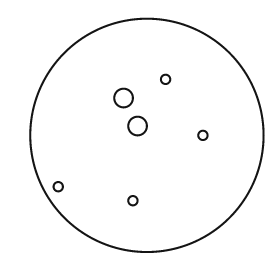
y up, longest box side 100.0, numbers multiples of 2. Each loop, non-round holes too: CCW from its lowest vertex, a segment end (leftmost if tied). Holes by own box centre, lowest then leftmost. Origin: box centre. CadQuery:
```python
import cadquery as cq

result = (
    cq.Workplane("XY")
    .moveTo(0.0, 0.0)
    .circle(50.0)
    .moveTo(-6.0, -28.0)
    .circle(2.0)
    .moveTo(-38.0, -22.0)
    .circle(2.0)
    .moveTo(24.0, 0.0)
    .circle(2.0)
    .moveTo(-4.0, 4.0)
    .circle(4.0)
    .moveTo(-10.0, 16.0)
    .circle(4.0)
    .moveTo(8.0, 24.0)
    .circle(2.0)
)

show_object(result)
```